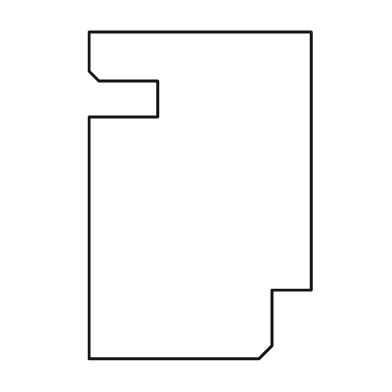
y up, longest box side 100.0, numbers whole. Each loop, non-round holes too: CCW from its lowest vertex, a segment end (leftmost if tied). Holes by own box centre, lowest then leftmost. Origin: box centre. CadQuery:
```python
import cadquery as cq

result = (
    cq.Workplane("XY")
    .moveTo(-34.0, -50.0)
    .lineTo(18.0, -50.0)
    .lineTo(22.0, -46.0)
    .lineTo(22.0, -29.0)
    .lineTo(34.0, -29.0)
    .lineTo(34.0, 50.0)
    .lineTo(-34.0, 50.0)
    .lineTo(-34.0, 38.0)
    .lineTo(-31.0, 35.0)
    .lineTo(-13.0, 35.0)
    .lineTo(-13.0, 24.0)
    .lineTo(-34.0, 24.0)
    .close()
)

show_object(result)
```